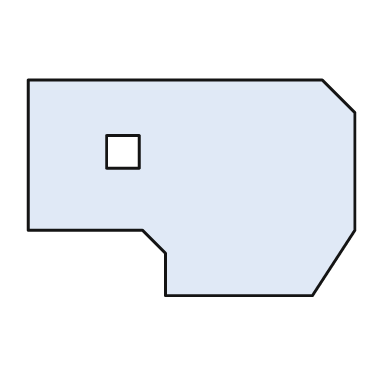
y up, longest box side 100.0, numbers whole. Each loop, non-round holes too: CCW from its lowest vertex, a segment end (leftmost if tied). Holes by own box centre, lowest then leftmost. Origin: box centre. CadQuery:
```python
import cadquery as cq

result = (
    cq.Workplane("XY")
    .moveTo(-8.0, -33.0)
    .lineTo(37.0, -33.0)
    .lineTo(50.0, -13.0)
    .lineTo(50.0, 23.0)
    .lineTo(40.0, 33.0)
    .lineTo(-50.0, 33.0)
    .lineTo(-50.0, -13.0)
    .lineTo(-15.0, -13.0)
    .lineTo(-8.0, -20.0)
    .close()
    .moveTo(-26.0, 6.0)
    .lineTo(-16.0, 6.0)
    .lineTo(-16.0, 16.0)
    .lineTo(-26.0, 16.0)
    .close()
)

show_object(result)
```